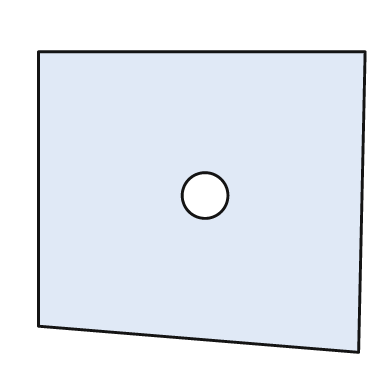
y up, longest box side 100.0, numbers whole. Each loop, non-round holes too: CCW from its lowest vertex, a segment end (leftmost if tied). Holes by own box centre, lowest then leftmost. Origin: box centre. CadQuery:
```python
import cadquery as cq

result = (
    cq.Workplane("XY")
    .moveTo(48.0, -46.0)
    .lineTo(50.0, 46.0)
    .lineTo(-50.0, 46.0)
    .lineTo(-50.0, -38.0)
    .close()
    .moveTo(1.0, 2.0)
    .circle(7.0)
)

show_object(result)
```